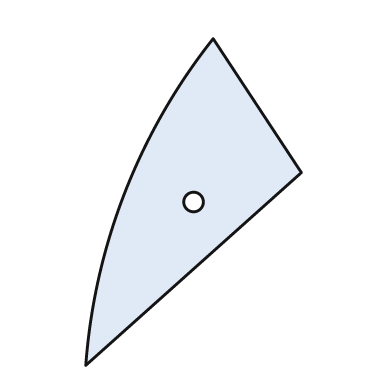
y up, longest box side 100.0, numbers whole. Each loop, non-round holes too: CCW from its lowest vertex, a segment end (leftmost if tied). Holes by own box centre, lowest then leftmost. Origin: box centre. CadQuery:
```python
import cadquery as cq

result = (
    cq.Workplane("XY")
    .moveTo(-33.0, -50.0)
    .lineTo(33.0, 9.0)
    .lineTo(6.0, 50.0)
    .threePointArc((-21.0, 3.0), (-33.0, -50.0))
    .close()
    .moveTo(0.0, 0.0)
    .circle(3.0)
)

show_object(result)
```